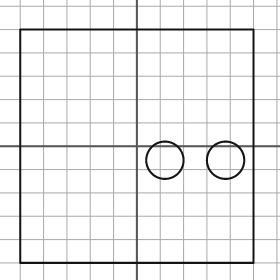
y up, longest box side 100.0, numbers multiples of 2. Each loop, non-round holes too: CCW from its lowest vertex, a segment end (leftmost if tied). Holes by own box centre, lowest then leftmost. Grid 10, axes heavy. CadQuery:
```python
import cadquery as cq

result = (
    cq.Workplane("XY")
    .moveTo(-50.0, -50.0)
    .lineTo(50.0, -50.0)
    .lineTo(50.0, 50.0)
    .lineTo(-50.0, 50.0)
    .close()
    .moveTo(12.0, -6.0)
    .circle(8.0)
    .moveTo(38.0, -6.0)
    .circle(8.0)
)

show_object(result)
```